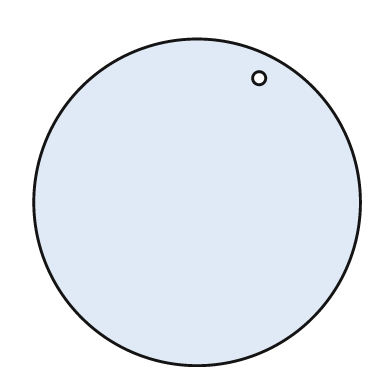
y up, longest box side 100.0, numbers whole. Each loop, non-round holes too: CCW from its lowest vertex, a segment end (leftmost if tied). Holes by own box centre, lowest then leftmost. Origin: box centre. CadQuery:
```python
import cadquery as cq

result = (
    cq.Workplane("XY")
    .moveTo(0.0, 0.0)
    .circle(50.0)
    .moveTo(19.0, 38.0)
    .circle(2.0)
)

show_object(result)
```